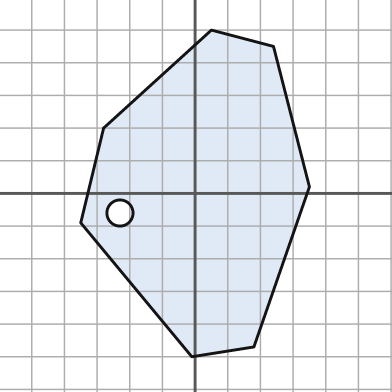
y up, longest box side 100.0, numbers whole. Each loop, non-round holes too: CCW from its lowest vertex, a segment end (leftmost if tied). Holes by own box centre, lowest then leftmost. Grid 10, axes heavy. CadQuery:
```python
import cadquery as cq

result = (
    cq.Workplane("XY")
    .moveTo(-1.0, -50.0)
    .lineTo(18.0, -47.0)
    .lineTo(35.0, 2.0)
    .lineTo(24.0, 45.0)
    .lineTo(5.0, 50.0)
    .lineTo(-28.0, 20.0)
    .lineTo(-35.0, -9.0)
    .close()
    .moveTo(-23.0, -6.0)
    .circle(4.0)
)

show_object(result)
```